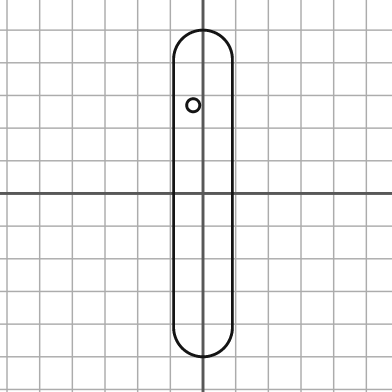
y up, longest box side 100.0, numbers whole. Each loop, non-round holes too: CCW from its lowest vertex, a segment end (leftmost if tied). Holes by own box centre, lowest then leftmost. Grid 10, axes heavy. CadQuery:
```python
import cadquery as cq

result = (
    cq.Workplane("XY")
    .moveTo(-9.0, -41.0)
    .threePointArc((0.0, -50.0), (9.0, -41.0))
    .lineTo(9.0, 41.0)
    .threePointArc((0.0, 50.0), (-9.0, 41.0))
    .close()
    .moveTo(-3.0, 27.0)
    .circle(2.0)
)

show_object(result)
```